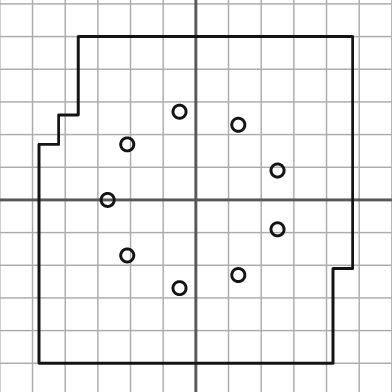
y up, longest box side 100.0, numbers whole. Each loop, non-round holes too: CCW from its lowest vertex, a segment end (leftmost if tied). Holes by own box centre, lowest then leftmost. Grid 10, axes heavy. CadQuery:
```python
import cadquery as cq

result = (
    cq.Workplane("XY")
    .moveTo(-48.0, -50.0)
    .lineTo(42.0, -50.0)
    .lineTo(42.0, -21.0)
    .lineTo(48.0, -21.0)
    .lineTo(48.0, 50.0)
    .lineTo(-36.0, 50.0)
    .lineTo(-36.0, 26.0)
    .lineTo(-42.0, 26.0)
    .lineTo(-42.0, 17.0)
    .lineTo(-48.0, 17.0)
    .close()
    .moveTo(-5.0, -27.0)
    .circle(2.0)
    .moveTo(13.0, -23.0)
    .circle(2.0)
    .moveTo(-21.0, -17.0)
    .circle(2.0)
    .moveTo(25.0, -9.0)
    .circle(2.0)
    .moveTo(-27.0, 0.0)
    .circle(2.0)
    .moveTo(25.0, 9.0)
    .circle(2.0)
    .moveTo(-21.0, 17.0)
    .circle(2.0)
    .moveTo(13.0, 23.0)
    .circle(2.0)
    .moveTo(-5.0, 27.0)
    .circle(2.0)
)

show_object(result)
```